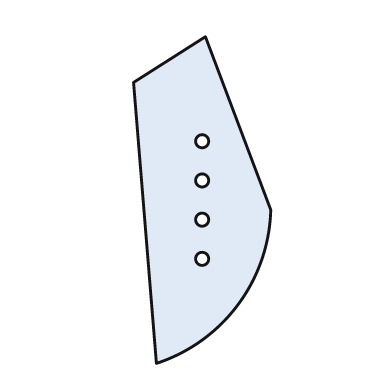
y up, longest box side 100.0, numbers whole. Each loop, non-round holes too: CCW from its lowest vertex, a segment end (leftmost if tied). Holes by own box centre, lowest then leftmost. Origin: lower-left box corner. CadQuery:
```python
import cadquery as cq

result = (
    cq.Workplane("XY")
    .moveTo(7.0, 0.0)
    .threePointArc((32.0, 18.0), (42.0, 47.0))
    .lineTo(22.0, 100.0)
    .lineTo(0.0, 86.0)
    .close()
    .moveTo(21.0, 32.0)
    .circle(2.0)
    .moveTo(21.0, 44.0)
    .circle(2.0)
    .moveTo(21.0, 56.0)
    .circle(2.0)
    .moveTo(21.0, 68.0)
    .circle(2.0)
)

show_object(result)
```